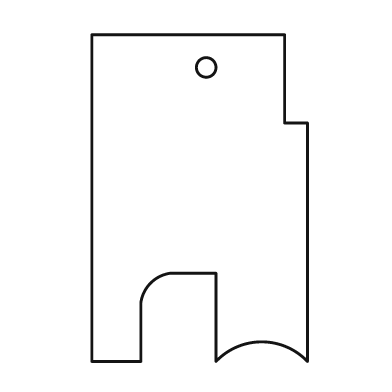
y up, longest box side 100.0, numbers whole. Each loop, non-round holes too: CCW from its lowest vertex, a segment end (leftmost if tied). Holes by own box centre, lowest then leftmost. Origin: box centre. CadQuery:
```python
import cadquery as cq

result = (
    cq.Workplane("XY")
    .moveTo(-33.0, -50.0)
    .lineTo(-18.0, -50.0)
    .lineTo(-18.0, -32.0)
    .threePointArc((-15.0, -26.0), (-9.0, -23.0))
    .lineTo(5.0, -23.0)
    .lineTo(5.0, -50.0)
    .threePointArc((19.0, -44.0), (33.0, -50.0))
    .lineTo(33.0, 23.0)
    .lineTo(26.0, 23.0)
    .lineTo(26.0, 50.0)
    .lineTo(-33.0, 50.0)
    .close()
    .moveTo(2.0, 40.0)
    .circle(3.0)
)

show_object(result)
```